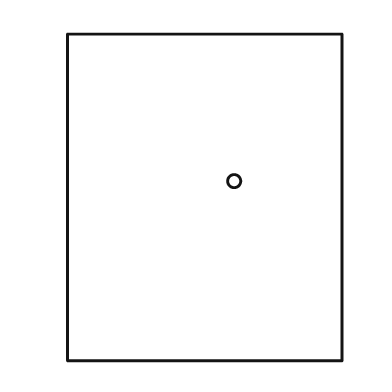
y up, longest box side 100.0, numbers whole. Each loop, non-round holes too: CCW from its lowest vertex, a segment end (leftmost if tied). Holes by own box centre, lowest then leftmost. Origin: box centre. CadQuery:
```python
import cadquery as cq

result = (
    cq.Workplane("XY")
    .moveTo(-42.0, -50.0)
    .lineTo(42.0, -50.0)
    .lineTo(42.0, 50.0)
    .lineTo(-42.0, 50.0)
    .close()
    .moveTo(9.0, 5.0)
    .circle(2.0)
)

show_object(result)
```